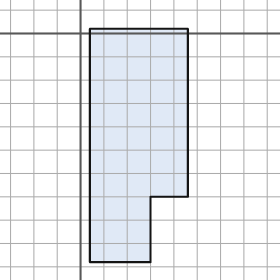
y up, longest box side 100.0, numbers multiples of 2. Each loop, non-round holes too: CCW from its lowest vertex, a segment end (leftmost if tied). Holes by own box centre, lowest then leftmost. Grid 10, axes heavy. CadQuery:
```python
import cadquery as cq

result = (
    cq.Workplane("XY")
    .moveTo(4.0, -98.0)
    .lineTo(30.0, -98.0)
    .lineTo(30.0, -70.0)
    .lineTo(46.0, -70.0)
    .lineTo(46.0, 2.0)
    .lineTo(4.0, 2.0)
    .close()
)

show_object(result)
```